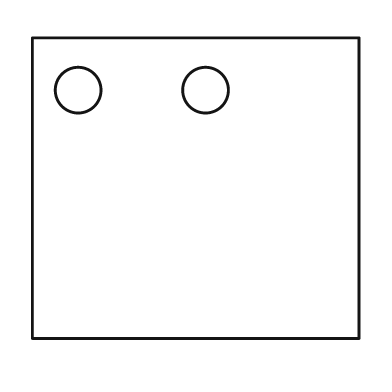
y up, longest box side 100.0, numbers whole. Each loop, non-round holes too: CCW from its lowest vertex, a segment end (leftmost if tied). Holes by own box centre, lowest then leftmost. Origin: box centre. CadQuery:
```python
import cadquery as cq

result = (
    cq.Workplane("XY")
    .moveTo(-50.0, -46.0)
    .lineTo(50.0, -46.0)
    .lineTo(50.0, 46.0)
    .lineTo(-50.0, 46.0)
    .close()
    .moveTo(-36.0, 30.0)
    .circle(7.0)
    .moveTo(3.0, 30.0)
    .circle(7.0)
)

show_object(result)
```